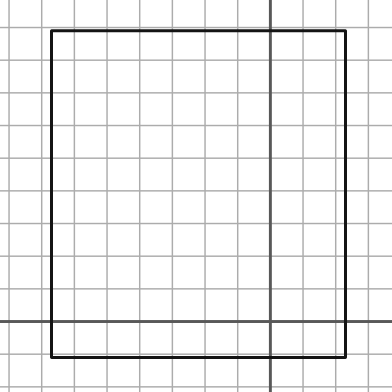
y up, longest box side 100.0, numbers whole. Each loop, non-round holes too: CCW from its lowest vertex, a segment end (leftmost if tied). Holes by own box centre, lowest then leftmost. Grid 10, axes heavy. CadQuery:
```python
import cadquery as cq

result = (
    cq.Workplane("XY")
    .moveTo(-67.0, -11.0)
    .lineTo(23.0, -11.0)
    .lineTo(23.0, 89.0)
    .lineTo(-67.0, 89.0)
    .close()
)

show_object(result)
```